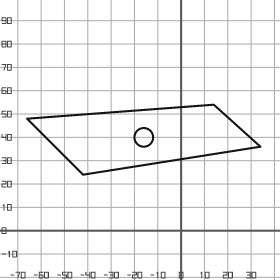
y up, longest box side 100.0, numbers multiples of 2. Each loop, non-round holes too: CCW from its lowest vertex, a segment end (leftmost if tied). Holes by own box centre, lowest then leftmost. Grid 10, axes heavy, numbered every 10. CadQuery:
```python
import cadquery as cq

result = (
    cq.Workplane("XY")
    .moveTo(-42.0, 24.0)
    .lineTo(34.0, 36.0)
    .lineTo(14.0, 54.0)
    .lineTo(-66.0, 48.0)
    .close()
    .moveTo(-16.0, 40.0)
    .circle(4.0)
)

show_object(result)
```